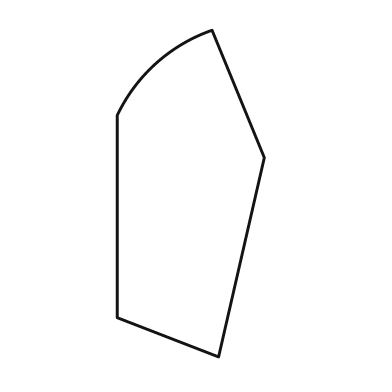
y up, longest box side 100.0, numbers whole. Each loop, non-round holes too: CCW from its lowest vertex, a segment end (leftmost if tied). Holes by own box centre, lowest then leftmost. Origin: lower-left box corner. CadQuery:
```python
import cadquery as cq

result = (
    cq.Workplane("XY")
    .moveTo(31.0, 0.0)
    .lineTo(45.0, 61.0)
    .lineTo(29.0, 100.0)
    .threePointArc((12.0, 90.0), (0.0, 74.0))
    .lineTo(0.0, 12.0)
    .close()
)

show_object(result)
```